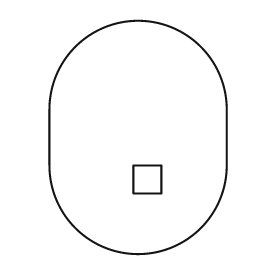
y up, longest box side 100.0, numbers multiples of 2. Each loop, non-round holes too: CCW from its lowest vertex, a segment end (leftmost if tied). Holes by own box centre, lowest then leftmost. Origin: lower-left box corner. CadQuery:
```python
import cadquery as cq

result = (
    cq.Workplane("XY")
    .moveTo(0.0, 38.0)
    .threePointArc((38.0, 0.0), (76.0, 38.0))
    .lineTo(76.0, 62.0)
    .threePointArc((38.0, 100.0), (0.0, 62.0))
    .close()
    .moveTo(36.0, 26.0)
    .lineTo(48.0, 26.0)
    .lineTo(48.0, 38.0)
    .lineTo(36.0, 38.0)
    .close()
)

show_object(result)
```